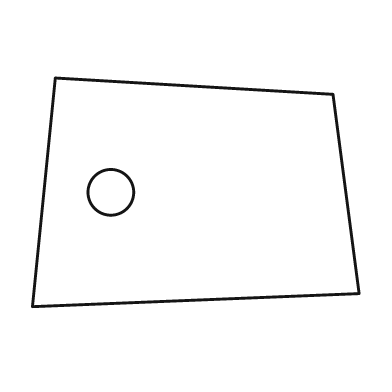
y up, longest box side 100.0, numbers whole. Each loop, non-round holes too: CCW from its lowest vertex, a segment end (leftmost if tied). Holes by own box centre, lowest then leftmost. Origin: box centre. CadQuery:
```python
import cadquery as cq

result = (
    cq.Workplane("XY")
    .moveTo(-50.0, -35.0)
    .lineTo(50.0, -31.0)
    .lineTo(42.0, 30.0)
    .lineTo(-43.0, 35.0)
    .close()
    .moveTo(-26.0, 0.0)
    .circle(7.0)
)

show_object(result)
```